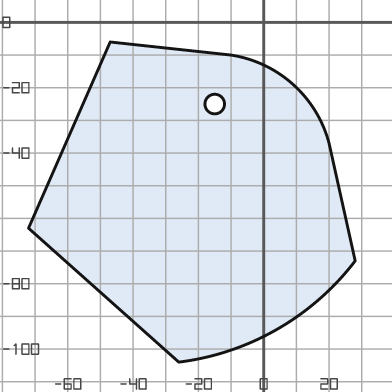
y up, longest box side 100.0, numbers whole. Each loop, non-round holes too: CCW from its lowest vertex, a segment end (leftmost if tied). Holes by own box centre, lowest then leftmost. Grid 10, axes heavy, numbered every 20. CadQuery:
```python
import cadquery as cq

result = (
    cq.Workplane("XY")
    .moveTo(-26.0, -104.0)
    .threePointArc((4.0, -94.0), (28.0, -73.0))
    .lineTo(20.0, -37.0)
    .threePointArc((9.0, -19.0), (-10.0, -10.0))
    .lineTo(-47.0, -6.0)
    .lineTo(-72.0, -63.0)
    .close()
    .moveTo(-15.0, -25.0)
    .circle(3.0)
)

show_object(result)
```